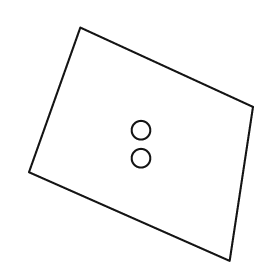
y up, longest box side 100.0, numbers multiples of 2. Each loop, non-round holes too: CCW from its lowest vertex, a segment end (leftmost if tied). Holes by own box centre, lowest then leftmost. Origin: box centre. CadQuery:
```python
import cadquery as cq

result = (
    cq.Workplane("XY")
    .moveTo(38.0, -50.0)
    .lineTo(48.0, 16.0)
    .lineTo(-26.0, 50.0)
    .lineTo(-48.0, -12.0)
    .close()
    .moveTo(0.0, -6.0)
    .circle(4.0)
    .moveTo(0.0, 6.0)
    .circle(4.0)
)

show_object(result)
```